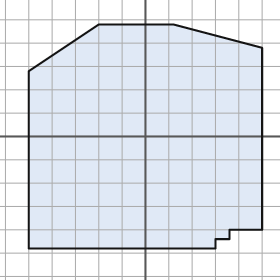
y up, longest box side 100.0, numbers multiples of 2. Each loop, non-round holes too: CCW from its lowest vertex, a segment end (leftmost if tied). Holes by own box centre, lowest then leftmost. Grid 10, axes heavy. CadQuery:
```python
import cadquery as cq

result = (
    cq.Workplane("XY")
    .moveTo(-50.0, -48.0)
    .lineTo(30.0, -48.0)
    .lineTo(30.0, -44.0)
    .lineTo(36.0, -44.0)
    .lineTo(36.0, -40.0)
    .lineTo(50.0, -40.0)
    .lineTo(50.0, 38.0)
    .lineTo(12.0, 48.0)
    .lineTo(-20.0, 48.0)
    .lineTo(-50.0, 28.0)
    .close()
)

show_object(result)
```